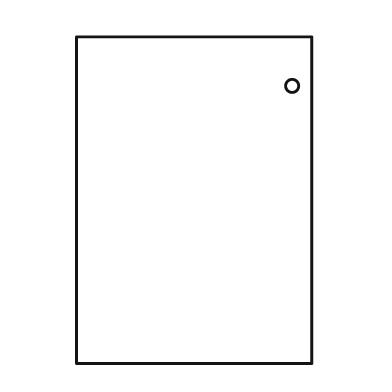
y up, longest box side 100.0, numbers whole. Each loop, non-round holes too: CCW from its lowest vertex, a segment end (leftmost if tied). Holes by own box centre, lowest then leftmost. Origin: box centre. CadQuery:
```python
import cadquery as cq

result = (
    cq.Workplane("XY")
    .moveTo(-36.0, -50.0)
    .lineTo(36.0, -50.0)
    .lineTo(36.0, 50.0)
    .lineTo(-36.0, 50.0)
    .close()
    .moveTo(30.0, 35.0)
    .circle(2.0)
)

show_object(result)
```